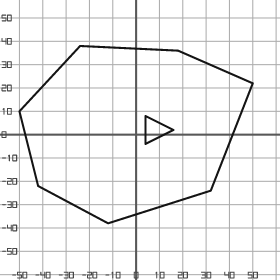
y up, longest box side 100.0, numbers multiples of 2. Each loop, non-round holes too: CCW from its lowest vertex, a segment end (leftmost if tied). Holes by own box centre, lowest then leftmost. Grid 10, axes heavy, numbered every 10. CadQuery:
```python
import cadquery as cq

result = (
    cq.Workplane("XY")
    .moveTo(-12.0, -38.0)
    .lineTo(32.0, -24.0)
    .lineTo(50.0, 22.0)
    .lineTo(18.0, 36.0)
    .lineTo(-24.0, 38.0)
    .lineTo(-50.0, 10.0)
    .lineTo(-42.0, -22.0)
    .close()
    .moveTo(4.0, -4.0)
    .lineTo(16.0, 2.0)
    .lineTo(4.0, 8.0)
    .close()
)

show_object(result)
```